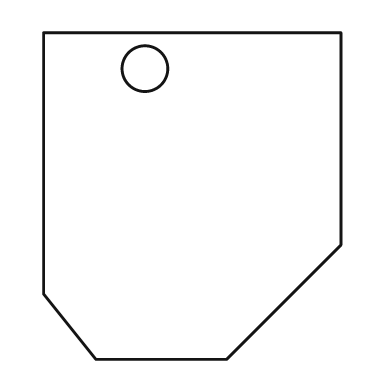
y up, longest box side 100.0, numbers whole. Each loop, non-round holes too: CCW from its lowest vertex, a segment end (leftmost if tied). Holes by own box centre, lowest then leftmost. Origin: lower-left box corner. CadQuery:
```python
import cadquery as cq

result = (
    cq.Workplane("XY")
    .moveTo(16.0, 0.0)
    .lineTo(56.0, 0.0)
    .lineTo(91.0, 35.0)
    .lineTo(91.0, 100.0)
    .lineTo(0.0, 100.0)
    .lineTo(0.0, 20.0)
    .close()
    .moveTo(31.0, 89.0)
    .circle(7.0)
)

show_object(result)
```